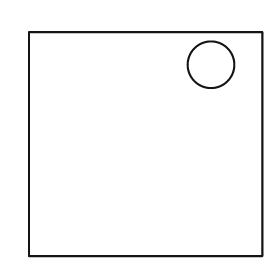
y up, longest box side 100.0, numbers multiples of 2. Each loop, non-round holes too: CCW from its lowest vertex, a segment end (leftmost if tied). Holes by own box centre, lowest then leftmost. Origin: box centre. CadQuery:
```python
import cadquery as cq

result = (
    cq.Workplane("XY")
    .moveTo(-50.0, -48.0)
    .lineTo(50.0, -48.0)
    .lineTo(50.0, 48.0)
    .lineTo(-50.0, 48.0)
    .close()
    .moveTo(28.0, 34.0)
    .circle(10.0)
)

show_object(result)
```